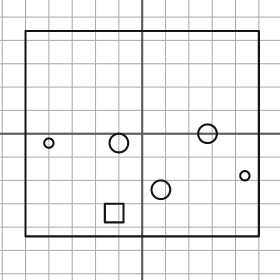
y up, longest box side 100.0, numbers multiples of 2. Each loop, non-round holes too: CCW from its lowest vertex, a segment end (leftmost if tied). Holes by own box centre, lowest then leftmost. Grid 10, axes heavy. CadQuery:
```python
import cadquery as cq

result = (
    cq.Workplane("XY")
    .moveTo(-50.0, -44.0)
    .lineTo(50.0, -44.0)
    .lineTo(50.0, 44.0)
    .lineTo(-50.0, 44.0)
    .close()
    .moveTo(-16.0, -38.0)
    .lineTo(-8.0, -38.0)
    .lineTo(-8.0, -30.0)
    .lineTo(-16.0, -30.0)
    .close()
    .moveTo(8.0, -24.0)
    .circle(4.0)
    .moveTo(44.0, -18.0)
    .circle(2.0)
    .moveTo(-40.0, -4.0)
    .circle(2.0)
    .moveTo(-10.0, -4.0)
    .circle(4.0)
    .moveTo(28.0, 0.0)
    .circle(4.0)
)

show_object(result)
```